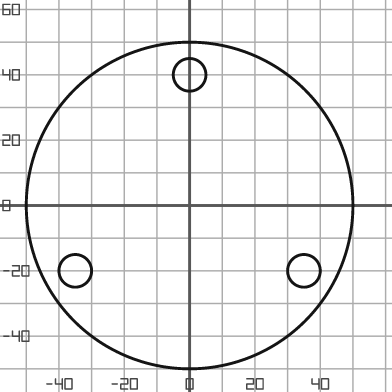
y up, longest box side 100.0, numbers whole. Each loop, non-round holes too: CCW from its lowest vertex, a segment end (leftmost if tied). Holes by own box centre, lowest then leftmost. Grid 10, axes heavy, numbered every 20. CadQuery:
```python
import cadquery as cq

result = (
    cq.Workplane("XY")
    .moveTo(0.0, 0.0)
    .circle(50.0)
    .moveTo(-35.0, -20.0)
    .circle(5.0)
    .moveTo(35.0, -20.0)
    .circle(5.0)
    .moveTo(0.0, 40.0)
    .circle(5.0)
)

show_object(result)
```